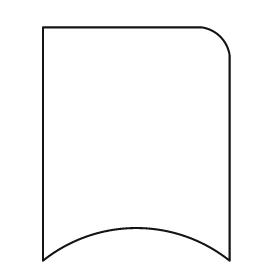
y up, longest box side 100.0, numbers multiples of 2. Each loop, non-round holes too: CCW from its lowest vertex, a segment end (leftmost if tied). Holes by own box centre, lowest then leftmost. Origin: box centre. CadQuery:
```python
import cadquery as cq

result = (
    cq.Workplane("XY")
    .moveTo(-40.0, -50.0)
    .threePointArc((0.0, -36.0), (40.0, -50.0))
    .lineTo(40.0, 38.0)
    .threePointArc((36.0, 46.0), (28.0, 50.0))
    .lineTo(-40.0, 50.0)
    .close()
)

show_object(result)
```